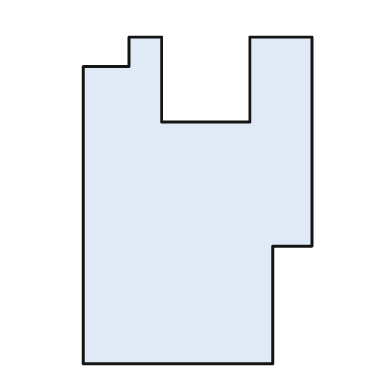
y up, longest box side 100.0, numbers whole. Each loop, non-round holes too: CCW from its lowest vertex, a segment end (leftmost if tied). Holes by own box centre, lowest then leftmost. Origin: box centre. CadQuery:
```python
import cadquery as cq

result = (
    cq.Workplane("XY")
    .moveTo(-35.0, -50.0)
    .lineTo(23.0, -50.0)
    .lineTo(23.0, -14.0)
    .lineTo(35.0, -14.0)
    .lineTo(35.0, 50.0)
    .lineTo(16.0, 50.0)
    .lineTo(16.0, 24.0)
    .lineTo(-11.0, 24.0)
    .lineTo(-11.0, 50.0)
    .lineTo(-21.0, 50.0)
    .lineTo(-21.0, 41.0)
    .lineTo(-35.0, 41.0)
    .close()
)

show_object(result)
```